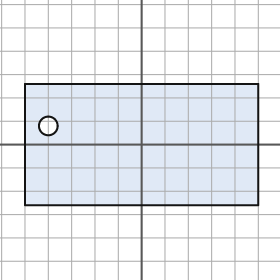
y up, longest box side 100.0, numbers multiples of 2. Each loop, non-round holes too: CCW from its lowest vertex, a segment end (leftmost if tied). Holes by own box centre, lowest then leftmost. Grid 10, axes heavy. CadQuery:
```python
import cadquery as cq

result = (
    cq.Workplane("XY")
    .moveTo(-50.0, -26.0)
    .lineTo(50.0, -26.0)
    .lineTo(50.0, 26.0)
    .lineTo(-50.0, 26.0)
    .close()
    .moveTo(-40.0, 8.0)
    .circle(4.0)
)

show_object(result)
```